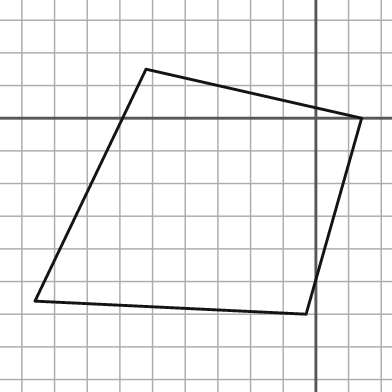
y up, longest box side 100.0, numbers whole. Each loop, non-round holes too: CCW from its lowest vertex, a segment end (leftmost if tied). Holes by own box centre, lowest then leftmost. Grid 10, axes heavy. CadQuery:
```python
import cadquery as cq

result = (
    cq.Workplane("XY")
    .moveTo(-3.0, -60.0)
    .lineTo(14.0, 0.0)
    .lineTo(-52.0, 15.0)
    .lineTo(-86.0, -56.0)
    .close()
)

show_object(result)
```